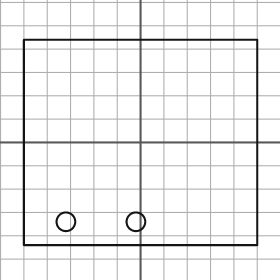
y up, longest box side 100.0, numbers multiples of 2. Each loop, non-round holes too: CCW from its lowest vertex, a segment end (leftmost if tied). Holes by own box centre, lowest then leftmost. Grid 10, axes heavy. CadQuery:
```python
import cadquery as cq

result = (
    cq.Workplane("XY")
    .moveTo(-50.0, -44.0)
    .lineTo(50.0, -44.0)
    .lineTo(50.0, 44.0)
    .lineTo(-50.0, 44.0)
    .close()
    .moveTo(-32.0, -34.0)
    .circle(4.0)
    .moveTo(-2.0, -34.0)
    .circle(4.0)
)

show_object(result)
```